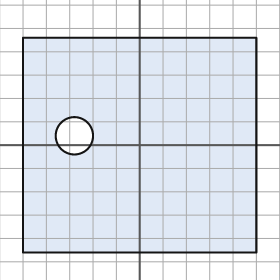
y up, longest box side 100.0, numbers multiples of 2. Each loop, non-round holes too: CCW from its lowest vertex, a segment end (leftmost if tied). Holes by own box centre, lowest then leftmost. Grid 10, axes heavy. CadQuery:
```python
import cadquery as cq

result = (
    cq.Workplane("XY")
    .moveTo(-50.0, -46.0)
    .lineTo(50.0, -46.0)
    .lineTo(50.0, 46.0)
    .lineTo(-50.0, 46.0)
    .close()
    .moveTo(-28.0, 4.0)
    .circle(8.0)
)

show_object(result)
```